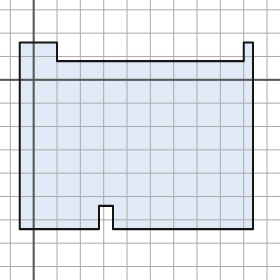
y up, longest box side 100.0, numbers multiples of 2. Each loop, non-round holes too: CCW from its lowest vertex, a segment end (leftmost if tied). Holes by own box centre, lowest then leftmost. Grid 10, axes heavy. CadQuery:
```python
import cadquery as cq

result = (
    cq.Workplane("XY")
    .moveTo(-6.0, -64.0)
    .lineTo(28.0, -64.0)
    .lineTo(28.0, -54.0)
    .lineTo(34.0, -54.0)
    .lineTo(34.0, -64.0)
    .lineTo(94.0, -64.0)
    .lineTo(94.0, 16.0)
    .lineTo(90.0, 16.0)
    .lineTo(90.0, 8.0)
    .lineTo(10.0, 8.0)
    .lineTo(10.0, 16.0)
    .lineTo(-6.0, 16.0)
    .close()
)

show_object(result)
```